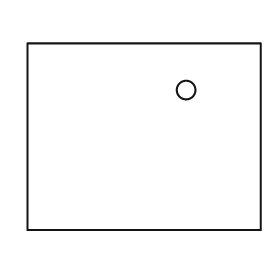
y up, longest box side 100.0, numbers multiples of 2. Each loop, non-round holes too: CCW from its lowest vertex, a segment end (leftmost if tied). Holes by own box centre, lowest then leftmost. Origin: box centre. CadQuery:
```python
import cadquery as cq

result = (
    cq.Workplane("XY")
    .moveTo(-50.0, -40.0)
    .lineTo(50.0, -40.0)
    .lineTo(50.0, 40.0)
    .lineTo(-50.0, 40.0)
    .close()
    .moveTo(18.0, 20.0)
    .circle(4.0)
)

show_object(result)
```